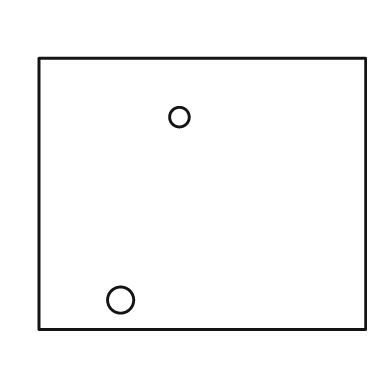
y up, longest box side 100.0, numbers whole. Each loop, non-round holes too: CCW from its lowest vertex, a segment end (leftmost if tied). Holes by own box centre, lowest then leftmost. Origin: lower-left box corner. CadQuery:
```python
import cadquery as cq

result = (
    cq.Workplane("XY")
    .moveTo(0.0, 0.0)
    .lineTo(100.0, 0.0)
    .lineTo(100.0, 83.0)
    .lineTo(0.0, 83.0)
    .close()
    .moveTo(25.0, 9.0)
    .circle(4.0)
    .moveTo(43.0, 65.0)
    .circle(3.0)
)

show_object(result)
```